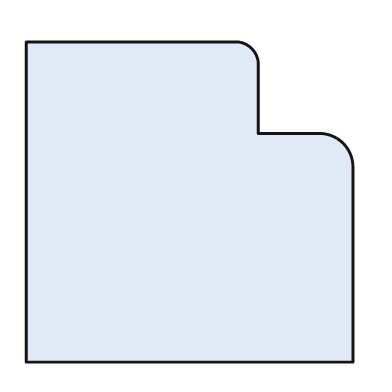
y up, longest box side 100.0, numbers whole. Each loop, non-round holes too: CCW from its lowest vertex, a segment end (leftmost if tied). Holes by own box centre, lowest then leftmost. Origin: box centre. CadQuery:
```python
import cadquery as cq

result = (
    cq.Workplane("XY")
    .moveTo(-50.0, -49.0)
    .lineTo(50.0, -49.0)
    .lineTo(50.0, 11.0)
    .threePointArc((47.0, 18.0), (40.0, 21.0))
    .lineTo(21.0, 21.0)
    .lineTo(21.0, 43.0)
    .threePointArc((19.0, 47.0), (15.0, 49.0))
    .lineTo(-50.0, 49.0)
    .close()
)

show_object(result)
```